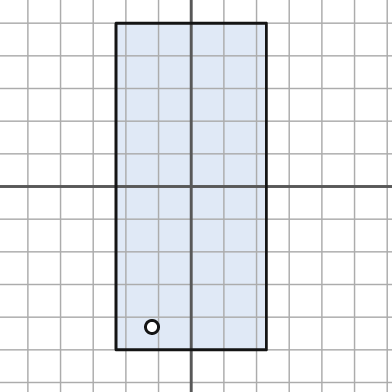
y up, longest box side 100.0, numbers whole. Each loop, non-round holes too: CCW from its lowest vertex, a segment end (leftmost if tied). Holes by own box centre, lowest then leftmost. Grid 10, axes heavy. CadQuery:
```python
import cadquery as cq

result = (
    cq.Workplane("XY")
    .moveTo(-23.0, -50.0)
    .lineTo(23.0, -50.0)
    .lineTo(23.0, 50.0)
    .lineTo(-23.0, 50.0)
    .close()
    .moveTo(-12.0, -43.0)
    .circle(2.0)
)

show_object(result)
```